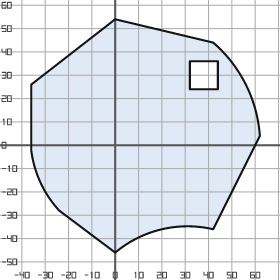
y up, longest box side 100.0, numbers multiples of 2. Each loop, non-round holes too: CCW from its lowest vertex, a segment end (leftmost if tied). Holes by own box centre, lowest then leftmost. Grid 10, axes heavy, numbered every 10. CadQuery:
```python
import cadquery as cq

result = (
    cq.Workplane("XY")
    .moveTo(0.0, -46.0)
    .threePointArc((20.0, -36.0), (42.0, -36.0))
    .lineTo(62.0, 4.0)
    .threePointArc((56.0, 26.0), (42.0, 44.0))
    .lineTo(0.0, 54.0)
    .lineTo(-36.0, 26.0)
    .lineTo(-36.0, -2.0)
    .threePointArc((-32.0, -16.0), (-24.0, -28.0))
    .close()
    .moveTo(32.0, 24.0)
    .lineTo(44.0, 24.0)
    .lineTo(44.0, 36.0)
    .lineTo(32.0, 36.0)
    .close()
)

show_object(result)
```